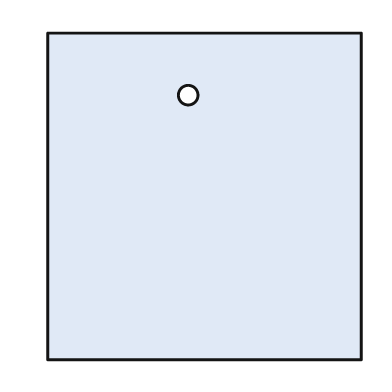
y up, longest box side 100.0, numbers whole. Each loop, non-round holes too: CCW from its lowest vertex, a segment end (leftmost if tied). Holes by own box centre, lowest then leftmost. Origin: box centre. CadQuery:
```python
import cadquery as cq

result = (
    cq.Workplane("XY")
    .moveTo(-48.0, -50.0)
    .lineTo(48.0, -50.0)
    .lineTo(48.0, 50.0)
    .lineTo(-48.0, 50.0)
    .close()
    .moveTo(-5.0, 31.0)
    .circle(3.0)
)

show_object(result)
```